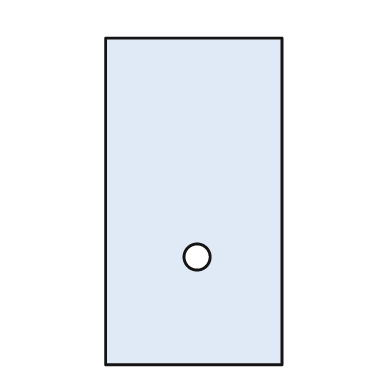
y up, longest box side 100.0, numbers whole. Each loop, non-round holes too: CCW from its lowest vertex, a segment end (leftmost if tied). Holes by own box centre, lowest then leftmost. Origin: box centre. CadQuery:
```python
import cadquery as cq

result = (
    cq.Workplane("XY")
    .moveTo(-27.0, -50.0)
    .lineTo(27.0, -50.0)
    .lineTo(27.0, 50.0)
    .lineTo(-27.0, 50.0)
    .close()
    .moveTo(1.0, -17.0)
    .circle(4.0)
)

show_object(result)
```